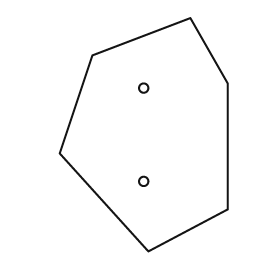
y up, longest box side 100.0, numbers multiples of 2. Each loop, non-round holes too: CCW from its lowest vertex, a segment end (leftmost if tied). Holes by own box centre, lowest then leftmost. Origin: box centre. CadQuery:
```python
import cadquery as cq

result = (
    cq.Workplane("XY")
    .moveTo(2.0, -50.0)
    .lineTo(36.0, -32.0)
    .lineTo(36.0, 22.0)
    .lineTo(20.0, 50.0)
    .lineTo(-22.0, 34.0)
    .lineTo(-36.0, -8.0)
    .close()
    .moveTo(0.0, -20.0)
    .circle(2.0)
    .moveTo(0.0, 20.0)
    .circle(2.0)
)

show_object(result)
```